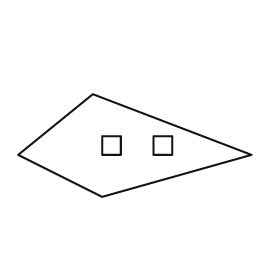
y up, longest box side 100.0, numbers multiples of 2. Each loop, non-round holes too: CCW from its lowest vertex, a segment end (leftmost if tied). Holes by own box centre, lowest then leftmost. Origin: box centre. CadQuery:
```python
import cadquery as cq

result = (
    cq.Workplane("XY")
    .moveTo(-14.0, -22.0)
    .lineTo(50.0, -4.0)
    .lineTo(-18.0, 22.0)
    .lineTo(-50.0, -4.0)
    .close()
    .moveTo(-14.0, -4.0)
    .lineTo(-6.0, -4.0)
    .lineTo(-6.0, 4.0)
    .lineTo(-14.0, 4.0)
    .close()
    .moveTo(8.0, -4.0)
    .lineTo(16.0, -4.0)
    .lineTo(16.0, 4.0)
    .lineTo(8.0, 4.0)
    .close()
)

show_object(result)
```